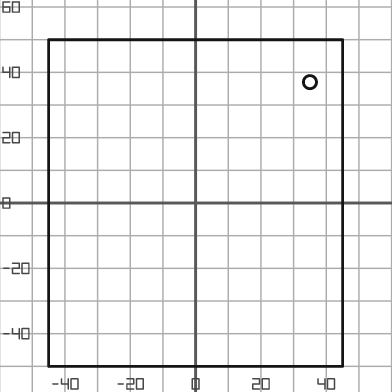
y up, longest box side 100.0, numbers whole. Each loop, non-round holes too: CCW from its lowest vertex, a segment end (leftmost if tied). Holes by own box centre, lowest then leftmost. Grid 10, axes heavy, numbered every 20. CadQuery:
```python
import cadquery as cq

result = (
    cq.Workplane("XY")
    .moveTo(-45.0, -50.0)
    .lineTo(45.0, -50.0)
    .lineTo(45.0, 50.0)
    .lineTo(-45.0, 50.0)
    .close()
    .moveTo(35.0, 37.0)
    .circle(2.0)
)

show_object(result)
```